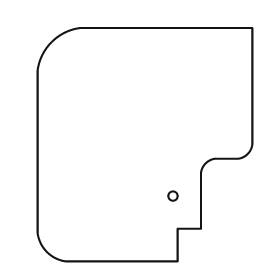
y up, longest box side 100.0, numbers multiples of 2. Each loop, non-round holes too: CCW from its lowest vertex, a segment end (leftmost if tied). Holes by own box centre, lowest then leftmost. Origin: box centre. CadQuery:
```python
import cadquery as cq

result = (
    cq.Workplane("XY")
    .moveTo(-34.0, -50.0)
    .lineTo(14.0, -50.0)
    .lineTo(14.0, -36.0)
    .lineTo(24.0, -36.0)
    .lineTo(24.0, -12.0)
    .threePointArc((26.0, -8.0), (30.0, -6.0))
    .lineTo(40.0, -6.0)
    .threePointArc((44.0, -4.0), (46.0, 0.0))
    .lineTo(46.0, 50.0)
    .lineTo(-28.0, 50.0)
    .threePointArc((-40.0, 44.0), (-46.0, 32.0))
    .lineTo(-46.0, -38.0)
    .threePointArc((-42.0, -46.0), (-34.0, -50.0))
    .close()
    .moveTo(12.0, -22.0)
    .circle(2.0)
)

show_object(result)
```